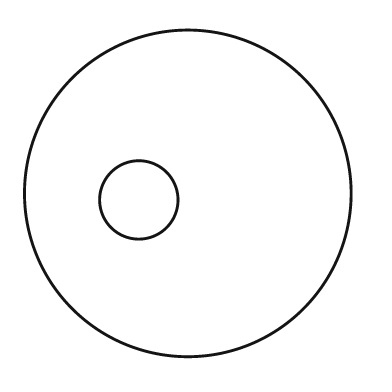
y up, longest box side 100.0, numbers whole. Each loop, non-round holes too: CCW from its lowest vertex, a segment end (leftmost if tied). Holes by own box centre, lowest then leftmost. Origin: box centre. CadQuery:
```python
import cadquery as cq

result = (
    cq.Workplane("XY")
    .moveTo(0.0, 0.0)
    .circle(50.0)
    .moveTo(-15.0, -2.0)
    .circle(12.0)
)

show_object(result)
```